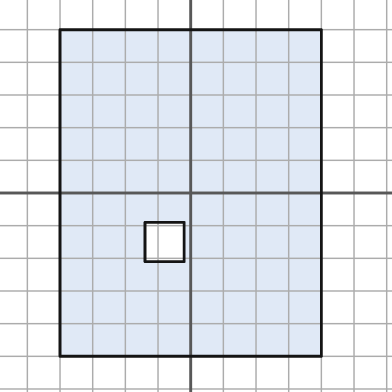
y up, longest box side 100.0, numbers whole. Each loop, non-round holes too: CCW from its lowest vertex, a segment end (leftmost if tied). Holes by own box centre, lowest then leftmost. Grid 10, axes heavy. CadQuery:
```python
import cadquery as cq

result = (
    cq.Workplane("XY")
    .moveTo(-40.0, -50.0)
    .lineTo(40.0, -50.0)
    .lineTo(40.0, 50.0)
    .lineTo(-40.0, 50.0)
    .close()
    .moveTo(-14.0, -21.0)
    .lineTo(-2.0, -21.0)
    .lineTo(-2.0, -9.0)
    .lineTo(-14.0, -9.0)
    .close()
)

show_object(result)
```